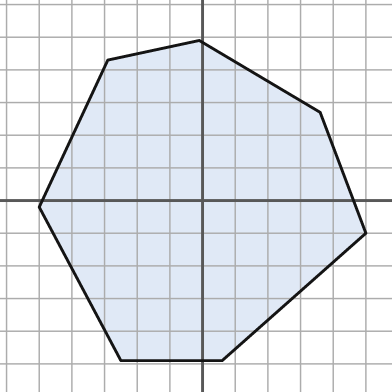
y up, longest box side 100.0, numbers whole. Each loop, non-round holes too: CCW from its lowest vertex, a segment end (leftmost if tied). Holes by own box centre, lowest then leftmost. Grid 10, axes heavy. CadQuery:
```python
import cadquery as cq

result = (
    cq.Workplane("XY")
    .moveTo(-25.0, -49.0)
    .lineTo(6.0, -49.0)
    .lineTo(50.0, -10.0)
    .lineTo(36.0, 27.0)
    .lineTo(-1.0, 49.0)
    .lineTo(-29.0, 43.0)
    .lineTo(-50.0, -2.0)
    .close()
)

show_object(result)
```